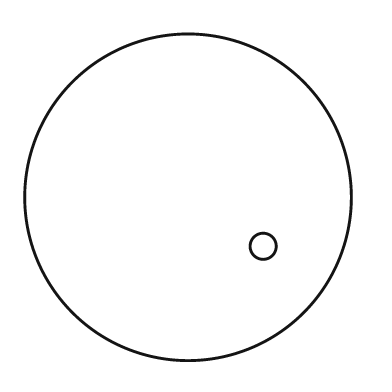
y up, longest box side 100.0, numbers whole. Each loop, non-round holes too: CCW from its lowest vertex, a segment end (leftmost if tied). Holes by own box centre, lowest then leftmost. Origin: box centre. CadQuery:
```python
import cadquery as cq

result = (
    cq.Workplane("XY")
    .moveTo(0.0, 0.0)
    .circle(50.0)
    .moveTo(23.0, -15.0)
    .circle(4.0)
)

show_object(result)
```